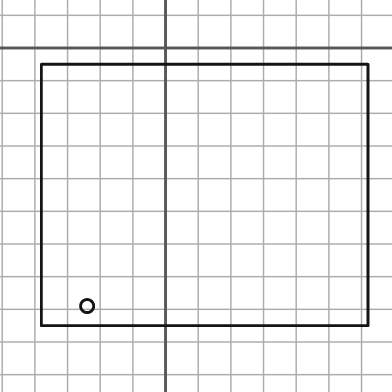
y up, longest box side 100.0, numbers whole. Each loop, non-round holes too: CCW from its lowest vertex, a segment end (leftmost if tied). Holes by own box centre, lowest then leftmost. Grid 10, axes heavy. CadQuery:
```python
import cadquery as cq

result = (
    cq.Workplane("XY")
    .moveTo(-38.0, -85.0)
    .lineTo(62.0, -85.0)
    .lineTo(62.0, -5.0)
    .lineTo(-38.0, -5.0)
    .close()
    .moveTo(-24.0, -79.0)
    .circle(2.0)
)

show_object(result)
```